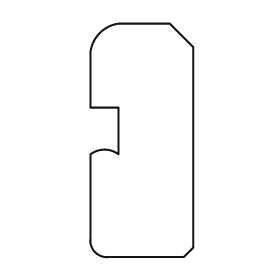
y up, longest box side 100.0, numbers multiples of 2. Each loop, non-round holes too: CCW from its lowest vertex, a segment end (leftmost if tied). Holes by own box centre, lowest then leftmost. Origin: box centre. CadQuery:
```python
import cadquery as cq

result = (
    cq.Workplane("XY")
    .moveTo(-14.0, -50.0)
    .lineTo(18.0, -50.0)
    .lineTo(22.0, -46.0)
    .lineTo(22.0, 40.0)
    .lineTo(12.0, 50.0)
    .lineTo(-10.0, 50.0)
    .threePointArc((-18.0, 46.0), (-22.0, 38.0))
    .lineTo(-22.0, 14.0)
    .lineTo(-10.0, 14.0)
    .lineTo(-10.0, -6.0)
    .threePointArc((-16.0, -4.0), (-22.0, -6.0))
    .lineTo(-22.0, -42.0)
    .threePointArc((-20.0, -48.0), (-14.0, -50.0))
    .close()
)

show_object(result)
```